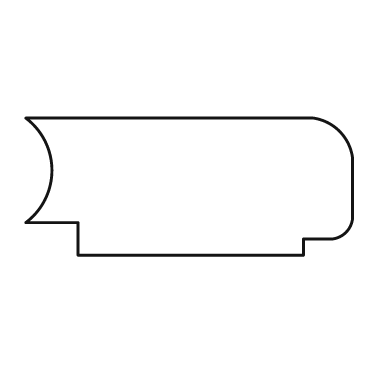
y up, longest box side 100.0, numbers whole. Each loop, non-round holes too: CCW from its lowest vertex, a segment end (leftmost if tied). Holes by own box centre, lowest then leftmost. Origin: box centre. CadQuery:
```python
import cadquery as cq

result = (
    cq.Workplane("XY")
    .moveTo(-34.0, -21.0)
    .lineTo(35.0, -21.0)
    .lineTo(35.0, -16.0)
    .lineTo(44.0, -16.0)
    .threePointArc((48.0, -14.0), (50.0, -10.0))
    .lineTo(50.0, 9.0)
    .threePointArc((46.0, 17.0), (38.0, 21.0))
    .lineTo(-50.0, 21.0)
    .threePointArc((-42.0, 5.0), (-50.0, -11.0))
    .lineTo(-34.0, -11.0)
    .close()
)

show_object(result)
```